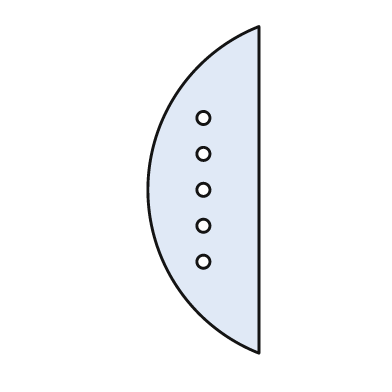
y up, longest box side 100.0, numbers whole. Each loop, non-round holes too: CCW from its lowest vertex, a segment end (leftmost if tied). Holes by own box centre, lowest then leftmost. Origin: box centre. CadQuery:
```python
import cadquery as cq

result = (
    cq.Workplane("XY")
    .moveTo(17.0, -50.0)
    .lineTo(17.0, 50.0)
    .threePointArc((-17.0, 0.0), (17.0, -50.0))
    .close()
    .moveTo(0.0, -22.0)
    .circle(2.0)
    .moveTo(0.0, -11.0)
    .circle(2.0)
    .moveTo(0.0, 0.0)
    .circle(2.0)
    .moveTo(0.0, 11.0)
    .circle(2.0)
    .moveTo(0.0, 22.0)
    .circle(2.0)
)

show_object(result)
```